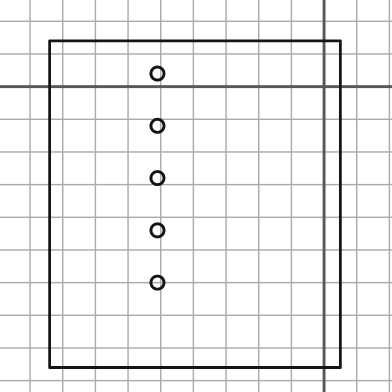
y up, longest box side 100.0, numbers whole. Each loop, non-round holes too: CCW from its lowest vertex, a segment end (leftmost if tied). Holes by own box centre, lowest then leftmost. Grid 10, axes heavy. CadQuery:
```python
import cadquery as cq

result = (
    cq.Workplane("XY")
    .moveTo(-84.0, -86.0)
    .lineTo(5.0, -86.0)
    .lineTo(5.0, 14.0)
    .lineTo(-84.0, 14.0)
    .close()
    .moveTo(-51.0, -60.0)
    .circle(2.0)
    .moveTo(-51.0, -44.0)
    .circle(2.0)
    .moveTo(-51.0, -28.0)
    .circle(2.0)
    .moveTo(-51.0, -12.0)
    .circle(2.0)
    .moveTo(-51.0, 4.0)
    .circle(2.0)
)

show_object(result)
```